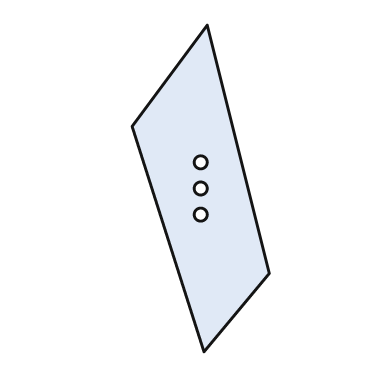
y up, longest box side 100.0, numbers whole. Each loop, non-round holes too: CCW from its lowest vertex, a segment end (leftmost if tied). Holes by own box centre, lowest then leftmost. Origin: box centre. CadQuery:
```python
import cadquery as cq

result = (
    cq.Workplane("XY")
    .moveTo(1.0, -50.0)
    .lineTo(21.0, -26.0)
    .lineTo(2.0, 50.0)
    .lineTo(-21.0, 19.0)
    .close()
    .moveTo(0.0, -8.0)
    .circle(2.0)
    .moveTo(0.0, 0.0)
    .circle(2.0)
    .moveTo(0.0, 8.0)
    .circle(2.0)
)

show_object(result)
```